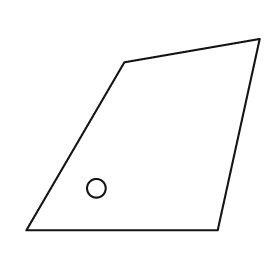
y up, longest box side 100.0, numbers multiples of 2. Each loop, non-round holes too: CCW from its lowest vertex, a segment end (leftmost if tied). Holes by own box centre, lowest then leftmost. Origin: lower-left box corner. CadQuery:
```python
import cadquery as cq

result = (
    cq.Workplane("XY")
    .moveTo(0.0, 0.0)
    .lineTo(82.0, 0.0)
    .lineTo(100.0, 82.0)
    .lineTo(42.0, 72.0)
    .close()
    .moveTo(30.0, 18.0)
    .circle(4.0)
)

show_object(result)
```